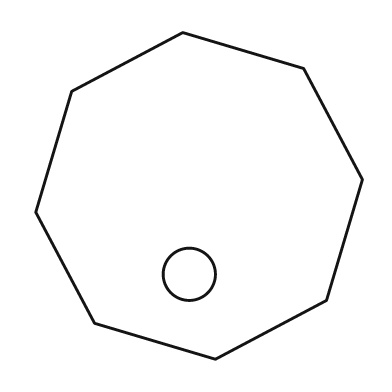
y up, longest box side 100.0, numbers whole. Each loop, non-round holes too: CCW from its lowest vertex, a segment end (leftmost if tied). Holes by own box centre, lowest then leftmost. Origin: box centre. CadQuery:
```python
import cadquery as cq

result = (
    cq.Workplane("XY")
    .moveTo(5.0, -50.0)
    .lineTo(39.0, -32.0)
    .lineTo(50.0, 5.0)
    .lineTo(32.0, 39.0)
    .lineTo(-5.0, 50.0)
    .lineTo(-39.0, 32.0)
    .lineTo(-50.0, -5.0)
    .lineTo(-32.0, -39.0)
    .close()
    .moveTo(-3.0, -24.0)
    .circle(8.0)
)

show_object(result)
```